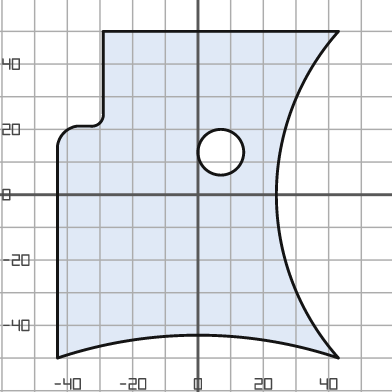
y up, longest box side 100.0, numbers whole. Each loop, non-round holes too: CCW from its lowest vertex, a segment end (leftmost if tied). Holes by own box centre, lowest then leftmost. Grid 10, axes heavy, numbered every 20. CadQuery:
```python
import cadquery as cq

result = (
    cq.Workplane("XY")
    .moveTo(-43.0, -50.0)
    .threePointArc((0.0, -43.0), (43.0, -50.0))
    .threePointArc((24.0, 0.0), (43.0, 50.0))
    .lineTo(-29.0, 50.0)
    .lineTo(-29.0, 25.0)
    .threePointArc((-30.0, 22.0), (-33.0, 21.0))
    .lineTo(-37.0, 21.0)
    .threePointArc((-41.0, 19.0), (-43.0, 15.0))
    .close()
    .moveTo(7.0, 13.0)
    .circle(7.0)
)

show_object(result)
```